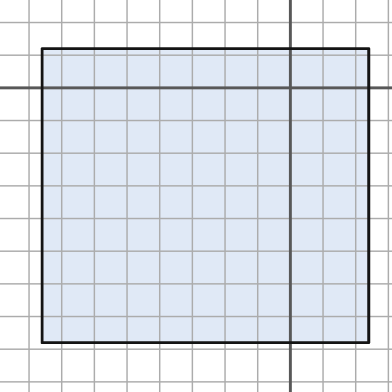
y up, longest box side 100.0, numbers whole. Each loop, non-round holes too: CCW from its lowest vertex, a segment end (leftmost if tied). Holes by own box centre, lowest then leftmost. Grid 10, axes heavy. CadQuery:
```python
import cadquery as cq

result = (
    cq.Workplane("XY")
    .moveTo(-76.0, -78.0)
    .lineTo(24.0, -78.0)
    .lineTo(24.0, 12.0)
    .lineTo(-76.0, 12.0)
    .close()
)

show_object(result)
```